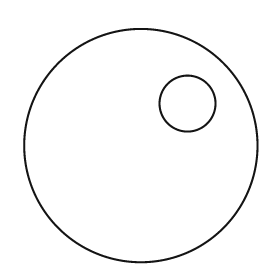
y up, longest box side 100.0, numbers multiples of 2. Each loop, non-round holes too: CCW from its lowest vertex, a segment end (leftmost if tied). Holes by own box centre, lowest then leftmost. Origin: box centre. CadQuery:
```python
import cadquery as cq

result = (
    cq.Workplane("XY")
    .moveTo(0.0, 0.0)
    .circle(50.0)
    .moveTo(20.0, 18.0)
    .circle(12.0)
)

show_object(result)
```